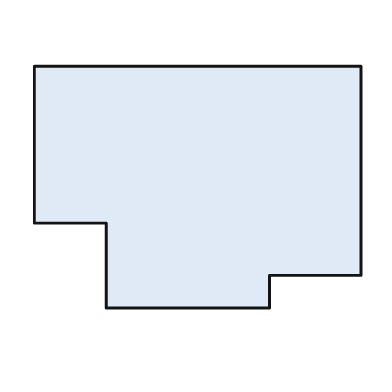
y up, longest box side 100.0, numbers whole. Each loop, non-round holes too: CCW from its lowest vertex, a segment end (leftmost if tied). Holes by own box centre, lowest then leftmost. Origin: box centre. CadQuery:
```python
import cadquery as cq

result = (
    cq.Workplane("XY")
    .moveTo(-28.0, -37.0)
    .lineTo(22.0, -37.0)
    .lineTo(22.0, -27.0)
    .lineTo(50.0, -27.0)
    .lineTo(50.0, 37.0)
    .lineTo(-50.0, 37.0)
    .lineTo(-50.0, -11.0)
    .lineTo(-28.0, -11.0)
    .close()
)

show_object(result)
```